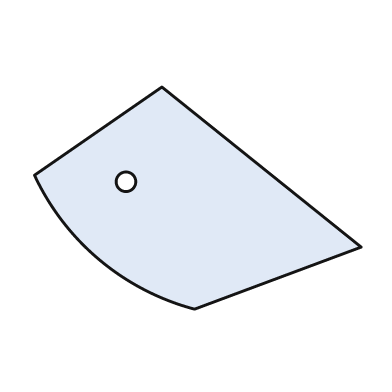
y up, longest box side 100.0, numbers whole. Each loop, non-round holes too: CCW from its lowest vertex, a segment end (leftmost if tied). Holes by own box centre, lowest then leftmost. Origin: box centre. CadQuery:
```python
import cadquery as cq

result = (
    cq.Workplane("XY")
    .moveTo(-1.0, -34.0)
    .lineTo(50.0, -15.0)
    .lineTo(-11.0, 34.0)
    .lineTo(-50.0, 7.0)
    .threePointArc((-30.0, -19.0), (-1.0, -34.0))
    .close()
    .moveTo(-22.0, 5.0)
    .circle(3.0)
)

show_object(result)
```